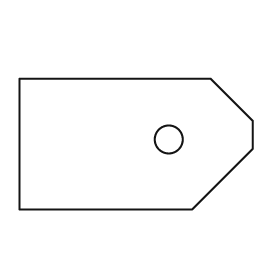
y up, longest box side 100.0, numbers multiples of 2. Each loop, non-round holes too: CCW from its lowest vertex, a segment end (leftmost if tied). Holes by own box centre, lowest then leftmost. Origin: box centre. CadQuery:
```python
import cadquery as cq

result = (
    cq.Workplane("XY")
    .moveTo(-50.0, -28.0)
    .lineTo(24.0, -28.0)
    .lineTo(50.0, -2.0)
    .lineTo(50.0, 10.0)
    .lineTo(32.0, 28.0)
    .lineTo(-50.0, 28.0)
    .close()
    .moveTo(14.0, 2.0)
    .circle(6.0)
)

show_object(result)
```